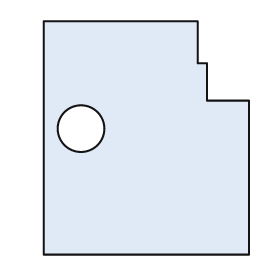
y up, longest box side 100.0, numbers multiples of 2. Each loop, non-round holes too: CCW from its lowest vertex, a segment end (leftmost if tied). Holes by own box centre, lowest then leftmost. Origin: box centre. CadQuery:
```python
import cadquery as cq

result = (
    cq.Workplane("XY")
    .moveTo(-44.0, -50.0)
    .lineTo(44.0, -50.0)
    .lineTo(44.0, 16.0)
    .lineTo(26.0, 16.0)
    .lineTo(26.0, 32.0)
    .lineTo(22.0, 32.0)
    .lineTo(22.0, 50.0)
    .lineTo(-44.0, 50.0)
    .close()
    .moveTo(-28.0, 4.0)
    .circle(10.0)
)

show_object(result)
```